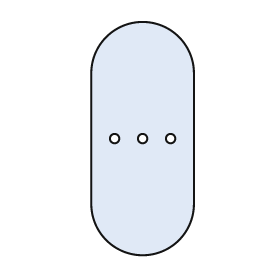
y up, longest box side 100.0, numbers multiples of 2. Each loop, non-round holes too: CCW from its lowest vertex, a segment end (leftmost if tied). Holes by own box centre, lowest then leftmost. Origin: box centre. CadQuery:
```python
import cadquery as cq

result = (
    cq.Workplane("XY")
    .moveTo(-22.0, -28.0)
    .threePointArc((0.0, -50.0), (22.0, -28.0))
    .lineTo(22.0, 28.0)
    .threePointArc((0.0, 50.0), (-22.0, 28.0))
    .close()
    .moveTo(-12.0, 0.0)
    .circle(2.0)
    .moveTo(0.0, 0.0)
    .circle(2.0)
    .moveTo(12.0, 0.0)
    .circle(2.0)
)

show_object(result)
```